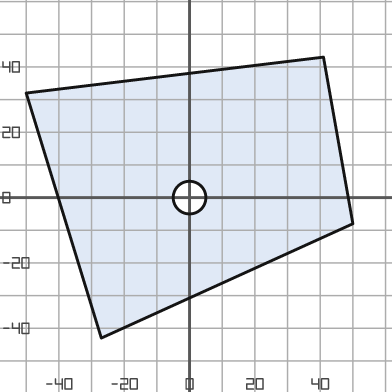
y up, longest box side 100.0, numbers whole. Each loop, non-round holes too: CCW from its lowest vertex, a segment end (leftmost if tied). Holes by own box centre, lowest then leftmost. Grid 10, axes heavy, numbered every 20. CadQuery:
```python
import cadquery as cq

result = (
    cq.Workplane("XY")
    .moveTo(-27.0, -43.0)
    .lineTo(50.0, -8.0)
    .lineTo(41.0, 43.0)
    .lineTo(-50.0, 32.0)
    .close()
    .moveTo(0.0, 0.0)
    .circle(5.0)
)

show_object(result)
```